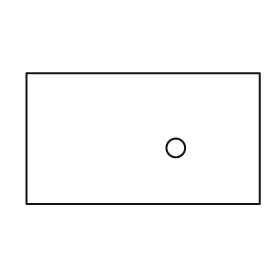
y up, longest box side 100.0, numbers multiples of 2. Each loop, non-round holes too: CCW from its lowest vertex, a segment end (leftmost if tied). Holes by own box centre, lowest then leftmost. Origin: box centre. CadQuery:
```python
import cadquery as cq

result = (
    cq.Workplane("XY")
    .moveTo(-50.0, -28.0)
    .lineTo(50.0, -28.0)
    .lineTo(50.0, 28.0)
    .lineTo(-50.0, 28.0)
    .close()
    .moveTo(14.0, -4.0)
    .circle(4.0)
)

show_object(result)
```